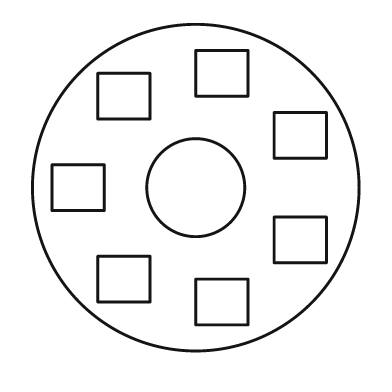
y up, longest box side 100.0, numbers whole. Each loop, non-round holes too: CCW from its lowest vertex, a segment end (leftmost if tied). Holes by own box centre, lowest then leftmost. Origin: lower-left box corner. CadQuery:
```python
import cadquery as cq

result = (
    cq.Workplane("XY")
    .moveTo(50.0, 50.0)
    .circle(50.0)
    .moveTo(50.0, 8.0)
    .lineTo(66.0, 8.0)
    .lineTo(66.0, 22.0)
    .lineTo(50.0, 22.0)
    .close()
    .moveTo(20.0, 15.0)
    .lineTo(36.0, 15.0)
    .lineTo(36.0, 29.0)
    .lineTo(20.0, 29.0)
    .close()
    .moveTo(74.0, 27.0)
    .lineTo(90.0, 27.0)
    .lineTo(90.0, 41.0)
    .lineTo(74.0, 41.0)
    .close()
    .moveTo(6.0, 43.0)
    .lineTo(22.0, 43.0)
    .lineTo(22.0, 57.0)
    .lineTo(6.0, 57.0)
    .close()
    .moveTo(50.0, 50.0)
    .circle(15.0)
    .moveTo(74.0, 59.0)
    .lineTo(90.0, 59.0)
    .lineTo(90.0, 73.0)
    .lineTo(74.0, 73.0)
    .close()
    .moveTo(20.0, 71.0)
    .lineTo(36.0, 71.0)
    .lineTo(36.0, 85.0)
    .lineTo(20.0, 85.0)
    .close()
    .moveTo(50.0, 78.0)
    .lineTo(66.0, 78.0)
    .lineTo(66.0, 92.0)
    .lineTo(50.0, 92.0)
    .close()
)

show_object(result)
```